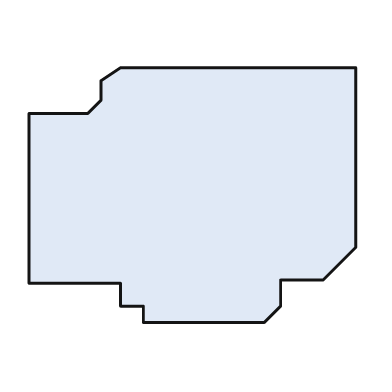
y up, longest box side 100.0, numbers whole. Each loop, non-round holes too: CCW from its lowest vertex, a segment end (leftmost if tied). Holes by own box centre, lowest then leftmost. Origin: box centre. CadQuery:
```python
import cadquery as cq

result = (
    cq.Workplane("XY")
    .moveTo(-15.0, -39.0)
    .lineTo(22.0, -39.0)
    .lineTo(27.0, -34.0)
    .lineTo(27.0, -26.0)
    .lineTo(40.0, -26.0)
    .lineTo(50.0, -16.0)
    .lineTo(50.0, 39.0)
    .lineTo(-22.0, 39.0)
    .lineTo(-28.0, 35.0)
    .lineTo(-28.0, 29.0)
    .lineTo(-32.0, 25.0)
    .lineTo(-50.0, 25.0)
    .lineTo(-50.0, -27.0)
    .lineTo(-22.0, -27.0)
    .lineTo(-22.0, -34.0)
    .lineTo(-15.0, -34.0)
    .close()
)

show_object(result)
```